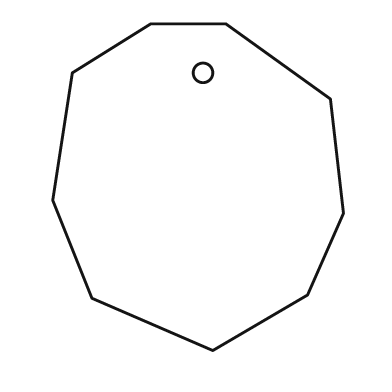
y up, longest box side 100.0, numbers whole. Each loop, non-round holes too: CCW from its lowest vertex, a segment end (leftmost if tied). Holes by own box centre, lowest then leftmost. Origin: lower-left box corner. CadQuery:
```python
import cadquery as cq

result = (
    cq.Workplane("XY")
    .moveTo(49.0, 0.0)
    .lineTo(78.0, 17.0)
    .lineTo(89.0, 42.0)
    .lineTo(85.0, 77.0)
    .lineTo(53.0, 100.0)
    .lineTo(30.0, 100.0)
    .lineTo(6.0, 85.0)
    .lineTo(0.0, 46.0)
    .lineTo(12.0, 16.0)
    .close()
    .moveTo(46.0, 85.0)
    .circle(3.0)
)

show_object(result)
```